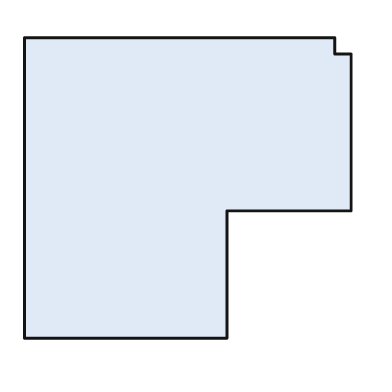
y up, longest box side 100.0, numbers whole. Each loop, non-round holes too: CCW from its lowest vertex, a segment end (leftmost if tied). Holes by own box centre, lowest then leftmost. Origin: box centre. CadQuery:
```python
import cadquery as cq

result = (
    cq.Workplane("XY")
    .moveTo(-50.0, -46.0)
    .lineTo(12.0, -46.0)
    .lineTo(12.0, -7.0)
    .lineTo(50.0, -7.0)
    .lineTo(50.0, 41.0)
    .lineTo(45.0, 41.0)
    .lineTo(45.0, 46.0)
    .lineTo(-50.0, 46.0)
    .close()
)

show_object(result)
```